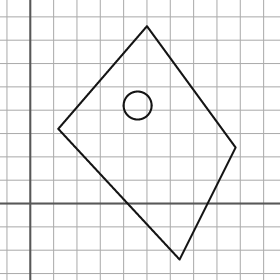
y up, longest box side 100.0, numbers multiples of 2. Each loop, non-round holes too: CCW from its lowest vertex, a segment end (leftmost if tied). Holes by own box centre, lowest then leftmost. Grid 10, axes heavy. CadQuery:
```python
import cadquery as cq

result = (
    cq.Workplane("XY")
    .moveTo(64.0, -24.0)
    .lineTo(88.0, 24.0)
    .lineTo(50.0, 76.0)
    .lineTo(12.0, 32.0)
    .close()
    .moveTo(46.0, 42.0)
    .circle(6.0)
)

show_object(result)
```